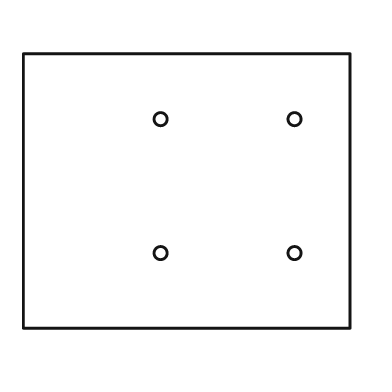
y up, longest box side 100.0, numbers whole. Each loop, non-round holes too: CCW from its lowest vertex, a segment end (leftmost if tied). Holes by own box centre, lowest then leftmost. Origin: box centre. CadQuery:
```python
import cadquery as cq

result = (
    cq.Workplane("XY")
    .moveTo(-50.0, -42.0)
    .lineTo(50.0, -42.0)
    .lineTo(50.0, 42.0)
    .lineTo(-50.0, 42.0)
    .close()
    .moveTo(-8.0, -19.0)
    .circle(2.0)
    .moveTo(33.0, -19.0)
    .circle(2.0)
    .moveTo(-8.0, 22.0)
    .circle(2.0)
    .moveTo(33.0, 22.0)
    .circle(2.0)
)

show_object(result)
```